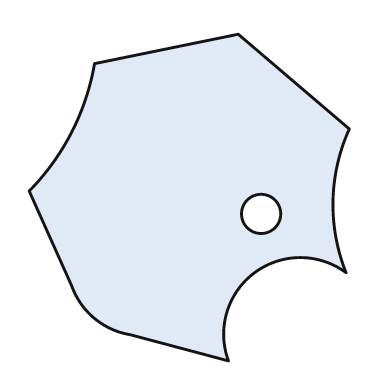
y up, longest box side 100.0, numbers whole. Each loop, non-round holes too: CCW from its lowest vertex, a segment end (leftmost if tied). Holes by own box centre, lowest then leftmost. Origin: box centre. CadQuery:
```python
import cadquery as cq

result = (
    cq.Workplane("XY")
    .moveTo(12.0, -50.0)
    .threePointArc((20.0, -23.0), (48.0, -23.0))
    .threePointArc((44.0, -1.0), (49.0, 21.0))
    .lineTo(15.0, 50.0)
    .lineTo(-29.0, 41.0)
    .threePointArc((-36.0, 20.0), (-49.0, 2.0))
    .lineTo(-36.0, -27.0)
    .threePointArc((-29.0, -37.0), (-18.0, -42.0))
    .close()
    .moveTo(22.0, -5.0)
    .circle(6.0)
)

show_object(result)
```